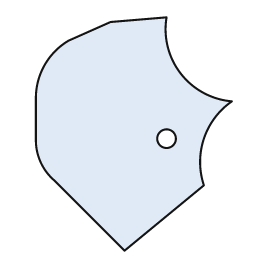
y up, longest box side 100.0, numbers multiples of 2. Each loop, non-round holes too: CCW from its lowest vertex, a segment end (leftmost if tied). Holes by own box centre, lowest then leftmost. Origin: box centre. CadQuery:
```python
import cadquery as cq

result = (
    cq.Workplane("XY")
    .moveTo(-4.0, -50.0)
    .lineTo(30.0, -22.0)
    .threePointArc((30.0, -2.0), (42.0, 14.0))
    .threePointArc((20.0, 26.0), (14.0, 50.0))
    .lineTo(-10.0, 48.0)
    .lineTo(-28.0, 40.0)
    .threePointArc((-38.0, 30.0), (-42.0, 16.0))
    .lineTo(-42.0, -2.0)
    .threePointArc((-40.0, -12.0), (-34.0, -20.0))
    .close()
    .moveTo(14.0, -2.0)
    .circle(4.0)
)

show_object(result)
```